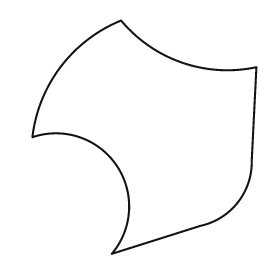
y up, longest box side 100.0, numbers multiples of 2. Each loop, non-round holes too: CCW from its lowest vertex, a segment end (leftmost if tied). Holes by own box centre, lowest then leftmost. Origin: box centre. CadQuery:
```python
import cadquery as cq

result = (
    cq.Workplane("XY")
    .moveTo(-14.0, -50.0)
    .lineTo(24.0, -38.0)
    .threePointArc((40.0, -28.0), (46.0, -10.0))
    .lineTo(48.0, 30.0)
    .threePointArc((16.0, 32.0), (-10.0, 50.0))
    .threePointArc((-36.0, 30.0), (-48.0, 0.0))
    .threePointArc((-12.0, -12.0), (-14.0, -50.0))
    .close()
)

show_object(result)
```